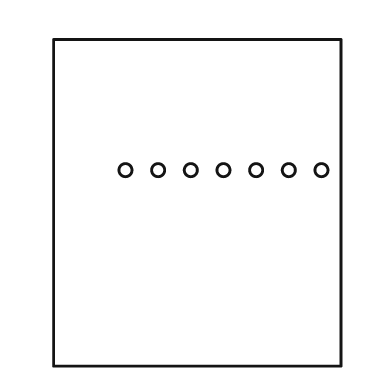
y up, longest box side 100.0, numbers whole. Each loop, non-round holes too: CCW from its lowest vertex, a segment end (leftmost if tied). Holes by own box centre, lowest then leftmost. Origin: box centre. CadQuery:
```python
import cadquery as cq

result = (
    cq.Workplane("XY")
    .moveTo(-44.0, -50.0)
    .lineTo(44.0, -50.0)
    .lineTo(44.0, 50.0)
    .lineTo(-44.0, 50.0)
    .close()
    .moveTo(-22.0, 10.0)
    .circle(2.0)
    .moveTo(-12.0, 10.0)
    .circle(2.0)
    .moveTo(-2.0, 10.0)
    .circle(2.0)
    .moveTo(8.0, 10.0)
    .circle(2.0)
    .moveTo(18.0, 10.0)
    .circle(2.0)
    .moveTo(28.0, 10.0)
    .circle(2.0)
    .moveTo(38.0, 10.0)
    .circle(2.0)
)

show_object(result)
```